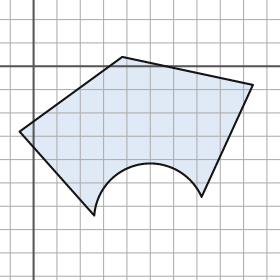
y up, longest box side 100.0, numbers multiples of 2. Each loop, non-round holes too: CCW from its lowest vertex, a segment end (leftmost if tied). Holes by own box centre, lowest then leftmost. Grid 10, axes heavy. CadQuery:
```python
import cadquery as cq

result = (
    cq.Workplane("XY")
    .moveTo(26.0, -64.0)
    .threePointArc((46.0, -42.0), (72.0, -56.0))
    .lineTo(94.0, -8.0)
    .lineTo(38.0, 4.0)
    .lineTo(-6.0, -28.0)
    .close()
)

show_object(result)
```